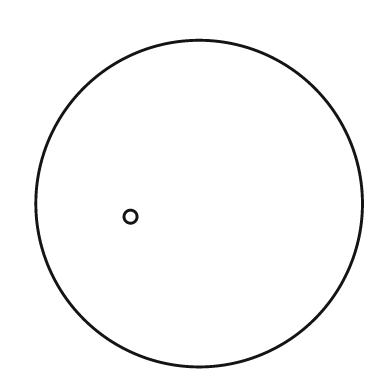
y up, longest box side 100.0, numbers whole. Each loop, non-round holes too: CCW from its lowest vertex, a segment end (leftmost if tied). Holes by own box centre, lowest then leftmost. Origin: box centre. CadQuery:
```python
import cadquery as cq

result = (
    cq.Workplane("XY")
    .moveTo(0.0, 0.0)
    .circle(50.0)
    .moveTo(-21.0, -4.0)
    .circle(2.0)
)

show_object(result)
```